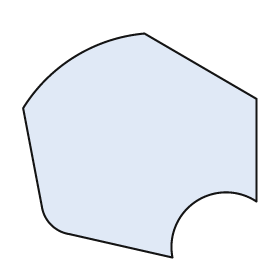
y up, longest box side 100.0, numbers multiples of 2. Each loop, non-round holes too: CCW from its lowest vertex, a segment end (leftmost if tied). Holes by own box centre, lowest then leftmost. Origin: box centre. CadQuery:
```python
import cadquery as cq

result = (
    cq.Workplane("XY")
    .moveTo(14.0, -48.0)
    .threePointArc((24.0, -24.0), (50.0, -24.0))
    .lineTo(50.0, 20.0)
    .lineTo(2.0, 48.0)
    .threePointArc((-28.0, 38.0), (-50.0, 16.0))
    .lineTo(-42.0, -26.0)
    .threePointArc((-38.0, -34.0), (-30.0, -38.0))
    .close()
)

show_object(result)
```